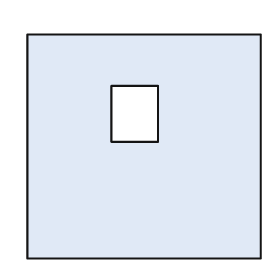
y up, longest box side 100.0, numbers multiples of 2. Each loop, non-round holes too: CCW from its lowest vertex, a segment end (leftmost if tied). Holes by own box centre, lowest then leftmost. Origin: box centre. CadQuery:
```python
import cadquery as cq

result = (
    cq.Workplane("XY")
    .moveTo(-50.0, -48.0)
    .lineTo(50.0, -48.0)
    .lineTo(50.0, 48.0)
    .lineTo(-50.0, 48.0)
    .close()
    .moveTo(-14.0, 2.0)
    .lineTo(6.0, 2.0)
    .lineTo(6.0, 26.0)
    .lineTo(-14.0, 26.0)
    .close()
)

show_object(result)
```